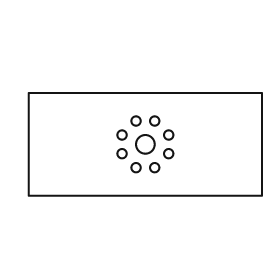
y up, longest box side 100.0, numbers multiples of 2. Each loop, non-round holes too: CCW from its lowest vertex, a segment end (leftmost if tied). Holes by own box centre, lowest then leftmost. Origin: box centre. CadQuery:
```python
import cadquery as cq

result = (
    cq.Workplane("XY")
    .moveTo(-50.0, -22.0)
    .lineTo(50.0, -22.0)
    .lineTo(50.0, 22.0)
    .lineTo(-50.0, 22.0)
    .close()
    .moveTo(-4.0, -10.0)
    .circle(2.0)
    .moveTo(4.0, -10.0)
    .circle(2.0)
    .moveTo(-10.0, -4.0)
    .circle(2.0)
    .moveTo(10.0, -4.0)
    .circle(2.0)
    .moveTo(0.0, 0.0)
    .circle(4.0)
    .moveTo(-10.0, 4.0)
    .circle(2.0)
    .moveTo(10.0, 4.0)
    .circle(2.0)
    .moveTo(-4.0, 10.0)
    .circle(2.0)
    .moveTo(4.0, 10.0)
    .circle(2.0)
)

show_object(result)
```